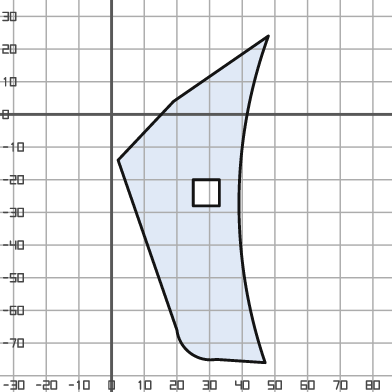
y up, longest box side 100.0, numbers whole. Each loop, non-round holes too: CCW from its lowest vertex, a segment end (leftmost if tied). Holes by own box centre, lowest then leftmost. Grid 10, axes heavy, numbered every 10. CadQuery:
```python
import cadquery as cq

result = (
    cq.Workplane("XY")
    .moveTo(47.0, -76.0)
    .threePointArc((39.0, -26.0), (48.0, 24.0))
    .lineTo(19.0, 4.0)
    .lineTo(2.0, -14.0)
    .lineTo(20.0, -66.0)
    .threePointArc((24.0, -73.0), (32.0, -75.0))
    .close()
    .moveTo(25.0, -28.0)
    .lineTo(33.0, -28.0)
    .lineTo(33.0, -20.0)
    .lineTo(25.0, -20.0)
    .close()
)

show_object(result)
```